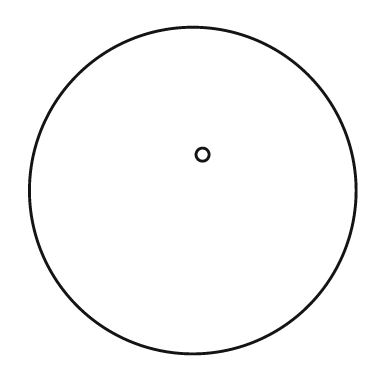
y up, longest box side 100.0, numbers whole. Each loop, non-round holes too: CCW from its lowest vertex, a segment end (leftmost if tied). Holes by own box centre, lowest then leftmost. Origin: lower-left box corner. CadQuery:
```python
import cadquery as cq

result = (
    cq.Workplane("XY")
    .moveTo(50.0, 50.0)
    .circle(50.0)
    .moveTo(53.0, 61.0)
    .circle(2.0)
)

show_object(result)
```